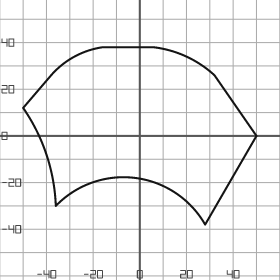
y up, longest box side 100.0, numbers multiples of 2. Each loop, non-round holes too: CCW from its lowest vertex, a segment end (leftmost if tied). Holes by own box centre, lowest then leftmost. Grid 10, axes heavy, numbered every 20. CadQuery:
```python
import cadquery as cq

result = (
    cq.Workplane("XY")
    .moveTo(28.0, -38.0)
    .lineTo(50.0, 0.0)
    .lineTo(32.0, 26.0)
    .threePointArc((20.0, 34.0), (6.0, 38.0))
    .lineTo(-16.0, 38.0)
    .threePointArc((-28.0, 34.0), (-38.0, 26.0))
    .lineTo(-50.0, 12.0)
    .threePointArc((-40.0, -8.0), (-36.0, -30.0))
    .threePointArc((-2.0, -18.0), (28.0, -38.0))
    .close()
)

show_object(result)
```